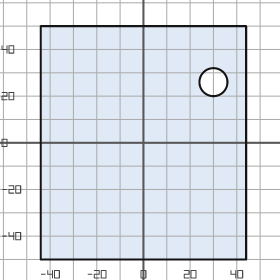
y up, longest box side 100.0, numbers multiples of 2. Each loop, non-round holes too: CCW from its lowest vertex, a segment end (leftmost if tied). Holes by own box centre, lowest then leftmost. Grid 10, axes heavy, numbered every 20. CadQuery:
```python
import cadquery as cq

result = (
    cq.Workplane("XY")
    .moveTo(-44.0, -50.0)
    .lineTo(44.0, -50.0)
    .lineTo(44.0, 50.0)
    .lineTo(-44.0, 50.0)
    .close()
    .moveTo(30.0, 26.0)
    .circle(6.0)
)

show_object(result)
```